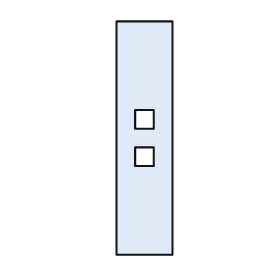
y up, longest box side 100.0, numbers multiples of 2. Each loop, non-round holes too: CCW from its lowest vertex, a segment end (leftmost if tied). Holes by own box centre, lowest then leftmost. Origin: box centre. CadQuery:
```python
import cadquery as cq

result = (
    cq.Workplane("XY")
    .moveTo(-12.0, -50.0)
    .lineTo(12.0, -50.0)
    .lineTo(12.0, 50.0)
    .lineTo(-12.0, 50.0)
    .close()
    .moveTo(-4.0, -12.0)
    .lineTo(4.0, -12.0)
    .lineTo(4.0, -4.0)
    .lineTo(-4.0, -4.0)
    .close()
    .moveTo(-4.0, 4.0)
    .lineTo(4.0, 4.0)
    .lineTo(4.0, 12.0)
    .lineTo(-4.0, 12.0)
    .close()
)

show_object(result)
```